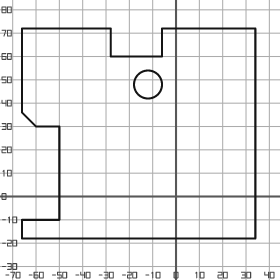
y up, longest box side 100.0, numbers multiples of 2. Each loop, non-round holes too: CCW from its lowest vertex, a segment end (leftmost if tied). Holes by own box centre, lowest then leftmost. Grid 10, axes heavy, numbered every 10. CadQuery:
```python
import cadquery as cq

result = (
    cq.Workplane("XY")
    .moveTo(-66.0, -18.0)
    .lineTo(34.0, -18.0)
    .lineTo(34.0, 72.0)
    .lineTo(-6.0, 72.0)
    .lineTo(-6.0, 60.0)
    .lineTo(-28.0, 60.0)
    .lineTo(-28.0, 72.0)
    .lineTo(-66.0, 72.0)
    .lineTo(-66.0, 36.0)
    .lineTo(-60.0, 30.0)
    .lineTo(-50.0, 30.0)
    .lineTo(-50.0, -10.0)
    .lineTo(-66.0, -10.0)
    .close()
    .moveTo(-12.0, 48.0)
    .circle(6.0)
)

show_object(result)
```